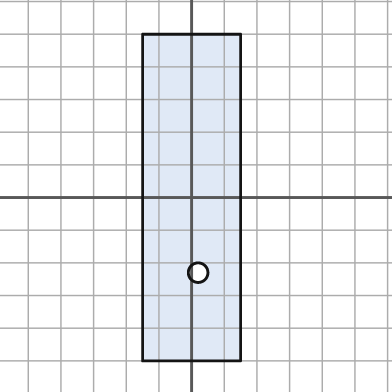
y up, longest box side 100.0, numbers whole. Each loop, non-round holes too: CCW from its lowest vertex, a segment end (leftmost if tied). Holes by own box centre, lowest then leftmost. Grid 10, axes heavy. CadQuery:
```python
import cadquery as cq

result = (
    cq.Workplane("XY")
    .moveTo(-15.0, -50.0)
    .lineTo(15.0, -50.0)
    .lineTo(15.0, 50.0)
    .lineTo(-15.0, 50.0)
    .close()
    .moveTo(2.0, -23.0)
    .circle(3.0)
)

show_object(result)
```